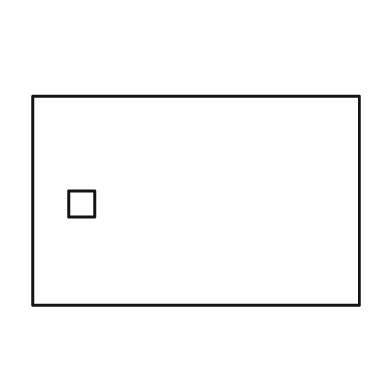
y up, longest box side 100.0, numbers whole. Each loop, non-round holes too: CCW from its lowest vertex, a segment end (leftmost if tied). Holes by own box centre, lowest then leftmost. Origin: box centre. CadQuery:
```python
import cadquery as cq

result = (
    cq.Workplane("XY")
    .moveTo(-50.0, -32.0)
    .lineTo(50.0, -32.0)
    .lineTo(50.0, 32.0)
    .lineTo(-50.0, 32.0)
    .close()
    .moveTo(-39.0, -5.0)
    .lineTo(-31.0, -5.0)
    .lineTo(-31.0, 3.0)
    .lineTo(-39.0, 3.0)
    .close()
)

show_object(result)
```